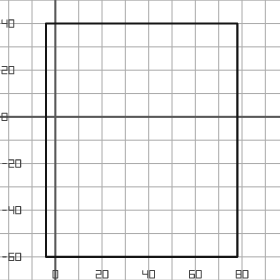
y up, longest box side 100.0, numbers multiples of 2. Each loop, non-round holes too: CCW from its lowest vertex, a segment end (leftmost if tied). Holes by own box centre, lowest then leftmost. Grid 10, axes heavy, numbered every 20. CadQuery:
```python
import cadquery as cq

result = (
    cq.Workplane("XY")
    .moveTo(-4.0, -60.0)
    .lineTo(78.0, -60.0)
    .lineTo(78.0, 40.0)
    .lineTo(-4.0, 40.0)
    .close()
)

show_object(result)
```